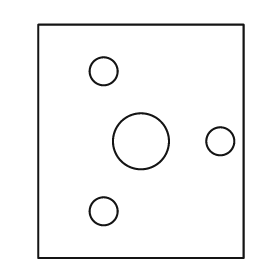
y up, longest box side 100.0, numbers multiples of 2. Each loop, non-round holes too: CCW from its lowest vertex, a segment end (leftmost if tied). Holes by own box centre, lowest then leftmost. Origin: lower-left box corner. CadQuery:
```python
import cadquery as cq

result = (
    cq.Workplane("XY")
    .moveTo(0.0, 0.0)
    .lineTo(88.0, 0.0)
    .lineTo(88.0, 100.0)
    .lineTo(0.0, 100.0)
    .close()
    .moveTo(28.0, 20.0)
    .circle(6.0)
    .moveTo(44.0, 50.0)
    .circle(12.0)
    .moveTo(78.0, 50.0)
    .circle(6.0)
    .moveTo(28.0, 80.0)
    .circle(6.0)
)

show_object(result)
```